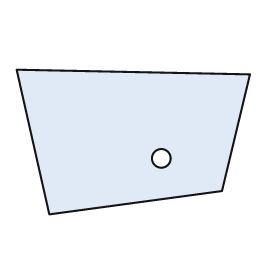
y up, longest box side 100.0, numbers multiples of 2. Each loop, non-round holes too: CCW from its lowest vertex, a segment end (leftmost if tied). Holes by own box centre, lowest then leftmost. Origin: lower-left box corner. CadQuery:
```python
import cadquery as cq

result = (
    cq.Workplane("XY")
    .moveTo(14.0, 0.0)
    .lineTo(88.0, 10.0)
    .lineTo(100.0, 60.0)
    .lineTo(0.0, 62.0)
    .close()
    .moveTo(62.0, 24.0)
    .circle(4.0)
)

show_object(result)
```